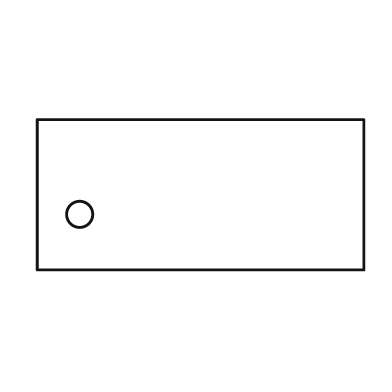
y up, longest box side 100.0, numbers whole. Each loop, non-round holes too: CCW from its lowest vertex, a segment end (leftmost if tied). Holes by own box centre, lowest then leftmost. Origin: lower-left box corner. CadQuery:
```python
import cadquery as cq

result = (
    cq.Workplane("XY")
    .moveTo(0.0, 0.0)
    .lineTo(100.0, 0.0)
    .lineTo(100.0, 46.0)
    .lineTo(0.0, 46.0)
    .close()
    .moveTo(13.0, 17.0)
    .circle(4.0)
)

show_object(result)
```